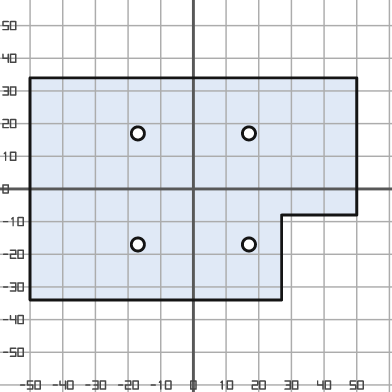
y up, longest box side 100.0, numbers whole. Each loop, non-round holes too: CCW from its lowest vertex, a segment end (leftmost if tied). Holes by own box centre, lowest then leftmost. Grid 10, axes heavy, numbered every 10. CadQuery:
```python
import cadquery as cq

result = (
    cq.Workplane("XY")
    .moveTo(-50.0, -34.0)
    .lineTo(27.0, -34.0)
    .lineTo(27.0, -8.0)
    .lineTo(50.0, -8.0)
    .lineTo(50.0, 34.0)
    .lineTo(-50.0, 34.0)
    .close()
    .moveTo(-17.0, -17.0)
    .circle(2.0)
    .moveTo(17.0, -17.0)
    .circle(2.0)
    .moveTo(-17.0, 17.0)
    .circle(2.0)
    .moveTo(17.0, 17.0)
    .circle(2.0)
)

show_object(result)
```